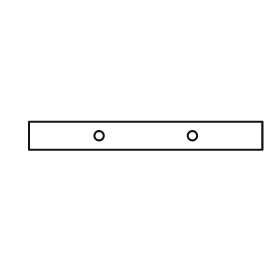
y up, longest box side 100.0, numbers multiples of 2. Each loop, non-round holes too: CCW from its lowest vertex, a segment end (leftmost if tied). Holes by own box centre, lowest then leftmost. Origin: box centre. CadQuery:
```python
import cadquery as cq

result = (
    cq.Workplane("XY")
    .moveTo(-50.0, -6.0)
    .lineTo(50.0, -6.0)
    .lineTo(50.0, 6.0)
    .lineTo(-50.0, 6.0)
    .close()
    .moveTo(-20.0, 0.0)
    .circle(2.0)
    .moveTo(20.0, 0.0)
    .circle(2.0)
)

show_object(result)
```